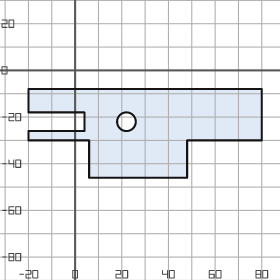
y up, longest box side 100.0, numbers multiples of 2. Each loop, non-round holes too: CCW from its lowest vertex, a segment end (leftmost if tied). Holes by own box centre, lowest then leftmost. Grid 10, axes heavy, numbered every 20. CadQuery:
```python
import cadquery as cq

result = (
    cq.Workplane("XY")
    .moveTo(6.0, -46.0)
    .lineTo(48.0, -46.0)
    .lineTo(48.0, -30.0)
    .lineTo(80.0, -30.0)
    .lineTo(80.0, -8.0)
    .lineTo(-20.0, -8.0)
    .lineTo(-20.0, -18.0)
    .lineTo(4.0, -18.0)
    .lineTo(4.0, -26.0)
    .lineTo(-20.0, -26.0)
    .lineTo(-20.0, -30.0)
    .lineTo(6.0, -30.0)
    .close()
    .moveTo(22.0, -22.0)
    .circle(4.0)
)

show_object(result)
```